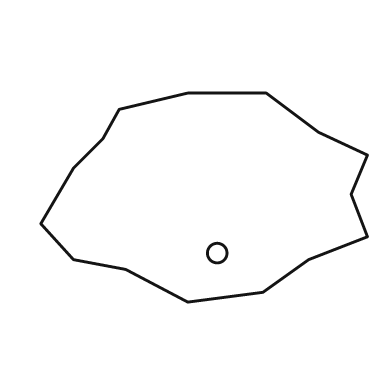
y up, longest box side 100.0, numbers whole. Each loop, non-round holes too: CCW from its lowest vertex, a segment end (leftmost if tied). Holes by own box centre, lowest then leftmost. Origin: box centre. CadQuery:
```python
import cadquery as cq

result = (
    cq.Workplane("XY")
    .moveTo(-5.0, -32.0)
    .lineTo(18.0, -29.0)
    .lineTo(32.0, -19.0)
    .lineTo(50.0, -12.0)
    .lineTo(45.0, 1.0)
    .lineTo(50.0, 13.0)
    .lineTo(35.0, 20.0)
    .lineTo(19.0, 32.0)
    .lineTo(-5.0, 32.0)
    .lineTo(-26.0, 27.0)
    .lineTo(-31.0, 18.0)
    .lineTo(-40.0, 9.0)
    .lineTo(-50.0, -8.0)
    .lineTo(-40.0, -19.0)
    .lineTo(-24.0, -22.0)
    .close()
    .moveTo(4.0, -17.0)
    .circle(3.0)
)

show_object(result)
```